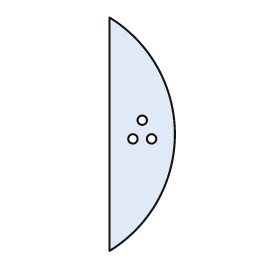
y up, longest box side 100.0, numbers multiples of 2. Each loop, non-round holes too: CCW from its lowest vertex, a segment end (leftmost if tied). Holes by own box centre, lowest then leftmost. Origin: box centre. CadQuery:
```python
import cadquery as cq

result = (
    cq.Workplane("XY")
    .moveTo(-14.0, -50.0)
    .threePointArc((14.0, 0.0), (-14.0, 50.0))
    .close()
    .moveTo(-4.0, -2.0)
    .circle(2.0)
    .moveTo(4.0, -2.0)
    .circle(2.0)
    .moveTo(0.0, 6.0)
    .circle(2.0)
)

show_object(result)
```